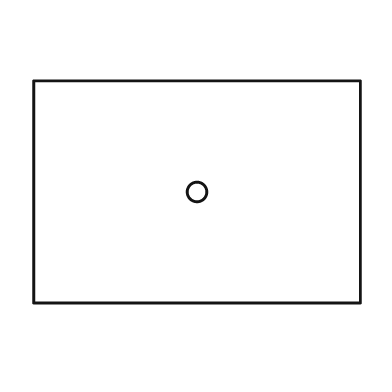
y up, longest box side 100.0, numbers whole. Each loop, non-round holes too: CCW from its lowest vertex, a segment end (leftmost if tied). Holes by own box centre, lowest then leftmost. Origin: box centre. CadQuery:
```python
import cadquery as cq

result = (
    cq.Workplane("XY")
    .moveTo(-50.0, -34.0)
    .lineTo(50.0, -34.0)
    .lineTo(50.0, 34.0)
    .lineTo(-50.0, 34.0)
    .close()
    .moveTo(0.0, 0.0)
    .circle(3.0)
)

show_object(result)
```